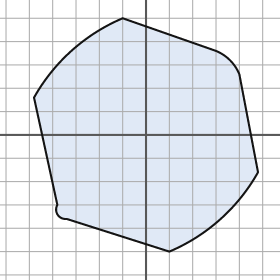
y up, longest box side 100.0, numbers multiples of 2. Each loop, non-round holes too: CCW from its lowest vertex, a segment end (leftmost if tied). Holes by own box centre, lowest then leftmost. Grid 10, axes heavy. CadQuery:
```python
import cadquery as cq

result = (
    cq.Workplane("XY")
    .moveTo(10.0, -50.0)
    .threePointArc((32.0, -36.0), (48.0, -16.0))
    .lineTo(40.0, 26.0)
    .threePointArc((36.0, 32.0), (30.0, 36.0))
    .lineTo(-10.0, 50.0)
    .threePointArc((-32.0, 36.0), (-48.0, 16.0))
    .lineTo(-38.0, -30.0)
    .threePointArc((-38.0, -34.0), (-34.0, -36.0))
    .close()
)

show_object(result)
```